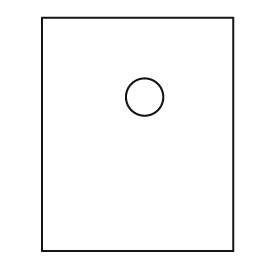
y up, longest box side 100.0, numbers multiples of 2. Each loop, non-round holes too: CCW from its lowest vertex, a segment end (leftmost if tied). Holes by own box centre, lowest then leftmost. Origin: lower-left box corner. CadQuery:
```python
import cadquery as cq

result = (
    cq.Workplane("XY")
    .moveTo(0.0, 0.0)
    .lineTo(82.0, 0.0)
    .lineTo(82.0, 100.0)
    .lineTo(0.0, 100.0)
    .close()
    .moveTo(44.0, 66.0)
    .circle(8.0)
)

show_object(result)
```